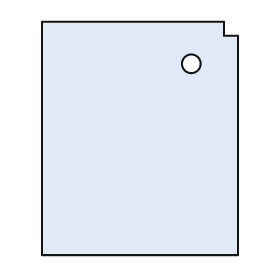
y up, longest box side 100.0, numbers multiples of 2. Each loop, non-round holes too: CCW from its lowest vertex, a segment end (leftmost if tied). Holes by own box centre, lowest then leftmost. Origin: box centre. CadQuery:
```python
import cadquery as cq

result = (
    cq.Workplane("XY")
    .moveTo(-42.0, -50.0)
    .lineTo(42.0, -50.0)
    .lineTo(42.0, 44.0)
    .lineTo(36.0, 44.0)
    .lineTo(36.0, 50.0)
    .lineTo(-42.0, 50.0)
    .close()
    .moveTo(22.0, 32.0)
    .circle(4.0)
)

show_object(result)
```